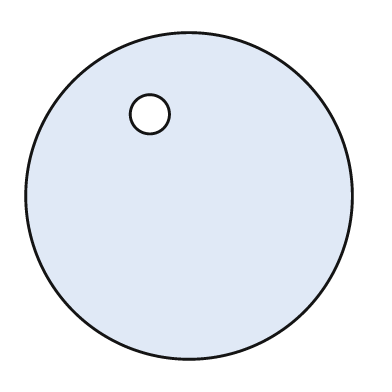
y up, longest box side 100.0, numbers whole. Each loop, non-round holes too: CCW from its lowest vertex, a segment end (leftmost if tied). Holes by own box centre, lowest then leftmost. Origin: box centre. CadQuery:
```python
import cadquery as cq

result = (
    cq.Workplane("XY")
    .moveTo(0.0, 0.0)
    .circle(50.0)
    .moveTo(-12.0, 25.0)
    .circle(6.0)
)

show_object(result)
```